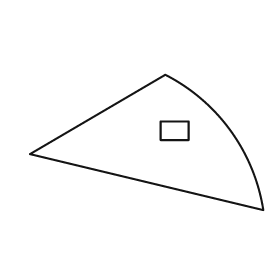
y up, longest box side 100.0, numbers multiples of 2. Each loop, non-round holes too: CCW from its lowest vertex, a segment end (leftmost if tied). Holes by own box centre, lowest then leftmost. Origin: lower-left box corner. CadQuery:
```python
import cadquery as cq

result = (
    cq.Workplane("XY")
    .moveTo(100.0, 0.0)
    .threePointArc((86.0, 34.0), (58.0, 58.0))
    .lineTo(0.0, 24.0)
    .close()
    .moveTo(56.0, 30.0)
    .lineTo(68.0, 30.0)
    .lineTo(68.0, 38.0)
    .lineTo(56.0, 38.0)
    .close()
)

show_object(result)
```